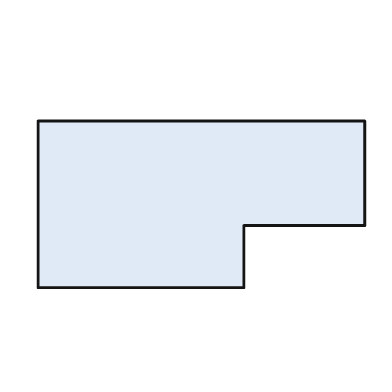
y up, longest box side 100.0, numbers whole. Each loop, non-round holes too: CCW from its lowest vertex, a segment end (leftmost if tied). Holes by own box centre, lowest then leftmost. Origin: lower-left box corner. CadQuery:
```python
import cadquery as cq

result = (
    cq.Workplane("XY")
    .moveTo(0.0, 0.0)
    .lineTo(63.0, 0.0)
    .lineTo(63.0, 19.0)
    .lineTo(100.0, 19.0)
    .lineTo(100.0, 51.0)
    .lineTo(0.0, 51.0)
    .close()
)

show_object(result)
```